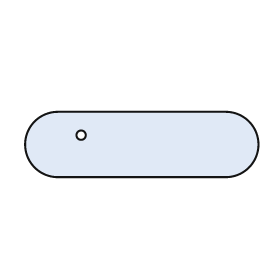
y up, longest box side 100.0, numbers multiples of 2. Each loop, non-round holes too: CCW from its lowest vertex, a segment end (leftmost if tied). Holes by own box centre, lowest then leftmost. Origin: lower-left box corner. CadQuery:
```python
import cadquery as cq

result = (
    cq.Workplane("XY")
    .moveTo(14.0, 0.0)
    .lineTo(86.0, 0.0)
    .threePointArc((100.0, 14.0), (86.0, 28.0))
    .lineTo(14.0, 28.0)
    .threePointArc((0.0, 14.0), (14.0, 0.0))
    .close()
    .moveTo(24.0, 18.0)
    .circle(2.0)
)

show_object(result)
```